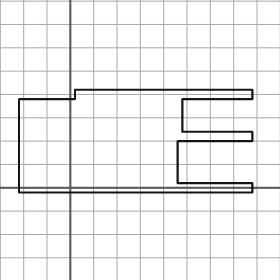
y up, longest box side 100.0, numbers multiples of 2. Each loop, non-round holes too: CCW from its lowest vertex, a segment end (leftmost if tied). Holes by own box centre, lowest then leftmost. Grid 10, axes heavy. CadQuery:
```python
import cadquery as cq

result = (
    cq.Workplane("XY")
    .moveTo(-22.0, -2.0)
    .lineTo(78.0, -2.0)
    .lineTo(78.0, 2.0)
    .lineTo(46.0, 2.0)
    .lineTo(46.0, 20.0)
    .lineTo(78.0, 20.0)
    .lineTo(78.0, 24.0)
    .lineTo(48.0, 24.0)
    .lineTo(48.0, 38.0)
    .lineTo(78.0, 38.0)
    .lineTo(78.0, 42.0)
    .lineTo(2.0, 42.0)
    .lineTo(2.0, 38.0)
    .lineTo(-22.0, 38.0)
    .close()
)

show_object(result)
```